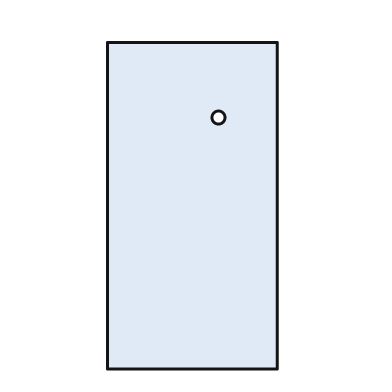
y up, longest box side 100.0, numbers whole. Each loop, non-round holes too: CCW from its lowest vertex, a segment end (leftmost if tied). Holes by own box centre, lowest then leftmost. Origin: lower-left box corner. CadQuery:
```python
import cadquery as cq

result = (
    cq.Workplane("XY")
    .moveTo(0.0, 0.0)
    .lineTo(52.0, 0.0)
    .lineTo(52.0, 100.0)
    .lineTo(0.0, 100.0)
    .close()
    .moveTo(34.0, 77.0)
    .circle(2.0)
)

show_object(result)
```